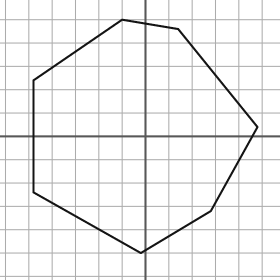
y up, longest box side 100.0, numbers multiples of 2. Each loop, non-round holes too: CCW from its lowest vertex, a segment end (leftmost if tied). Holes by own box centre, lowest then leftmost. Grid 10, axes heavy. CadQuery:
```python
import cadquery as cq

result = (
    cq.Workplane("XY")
    .moveTo(-2.0, -50.0)
    .lineTo(28.0, -32.0)
    .lineTo(48.0, 4.0)
    .lineTo(14.0, 46.0)
    .lineTo(-10.0, 50.0)
    .lineTo(-48.0, 24.0)
    .lineTo(-48.0, -24.0)
    .close()
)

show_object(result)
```